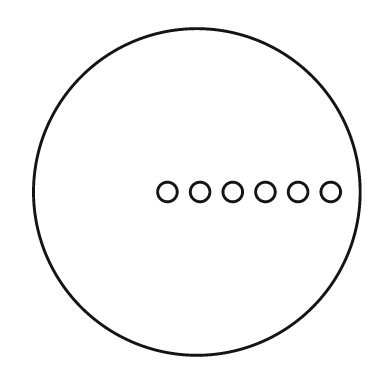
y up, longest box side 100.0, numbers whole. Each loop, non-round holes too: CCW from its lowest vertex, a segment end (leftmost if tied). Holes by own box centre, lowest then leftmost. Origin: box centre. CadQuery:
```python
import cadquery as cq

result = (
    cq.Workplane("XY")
    .moveTo(0.0, 0.0)
    .circle(50.0)
    .moveTo(-9.0, 0.0)
    .circle(3.0)
    .moveTo(1.0, 0.0)
    .circle(3.0)
    .moveTo(11.0, 0.0)
    .circle(3.0)
    .moveTo(21.0, 0.0)
    .circle(3.0)
    .moveTo(31.0, 0.0)
    .circle(3.0)
    .moveTo(41.0, 0.0)
    .circle(3.0)
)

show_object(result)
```